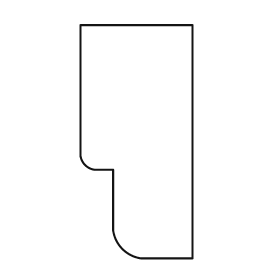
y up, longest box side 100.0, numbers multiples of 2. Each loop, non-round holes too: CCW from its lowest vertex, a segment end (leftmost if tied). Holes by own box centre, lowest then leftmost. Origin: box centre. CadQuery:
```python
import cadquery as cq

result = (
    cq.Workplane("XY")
    .moveTo(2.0, -50.0)
    .lineTo(24.0, -50.0)
    .lineTo(24.0, 50.0)
    .lineTo(-24.0, 50.0)
    .lineTo(-24.0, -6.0)
    .threePointArc((-22.0, -10.0), (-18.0, -12.0))
    .lineTo(-10.0, -12.0)
    .lineTo(-10.0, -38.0)
    .threePointArc((-6.0, -46.0), (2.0, -50.0))
    .close()
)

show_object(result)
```